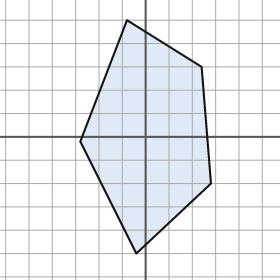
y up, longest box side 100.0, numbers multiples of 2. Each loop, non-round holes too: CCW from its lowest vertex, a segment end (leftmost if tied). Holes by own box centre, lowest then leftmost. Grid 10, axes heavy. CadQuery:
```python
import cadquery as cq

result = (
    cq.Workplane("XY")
    .moveTo(-4.0, -50.0)
    .lineTo(28.0, -20.0)
    .lineTo(24.0, 30.0)
    .lineTo(-8.0, 50.0)
    .lineTo(-28.0, -2.0)
    .close()
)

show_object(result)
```